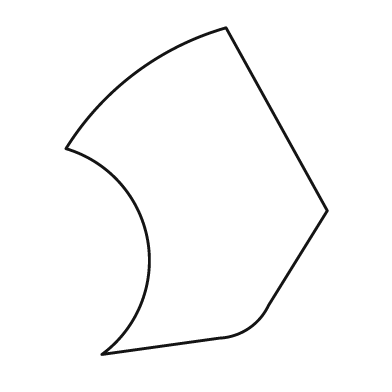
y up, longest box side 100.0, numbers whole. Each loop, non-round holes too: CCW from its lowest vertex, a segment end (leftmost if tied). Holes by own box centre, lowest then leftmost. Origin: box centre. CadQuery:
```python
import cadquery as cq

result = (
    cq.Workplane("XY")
    .moveTo(-29.0, -50.0)
    .lineTo(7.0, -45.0)
    .threePointArc((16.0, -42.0), (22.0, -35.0))
    .lineTo(40.0, -6.0)
    .lineTo(9.0, 50.0)
    .threePointArc((-19.0, 36.0), (-40.0, 13.0))
    .threePointArc((-15.0, -15.0), (-29.0, -50.0))
    .close()
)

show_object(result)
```